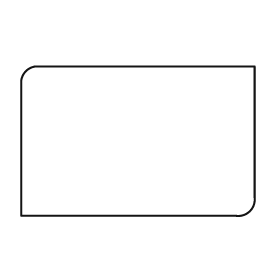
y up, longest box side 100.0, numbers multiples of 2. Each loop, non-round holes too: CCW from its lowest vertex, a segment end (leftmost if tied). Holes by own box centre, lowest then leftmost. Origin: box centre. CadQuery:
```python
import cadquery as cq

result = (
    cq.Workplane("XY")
    .moveTo(-50.0, -32.0)
    .lineTo(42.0, -32.0)
    .threePointArc((48.0, -30.0), (50.0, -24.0))
    .lineTo(50.0, 32.0)
    .lineTo(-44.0, 32.0)
    .threePointArc((-48.0, 30.0), (-50.0, 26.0))
    .close()
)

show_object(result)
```